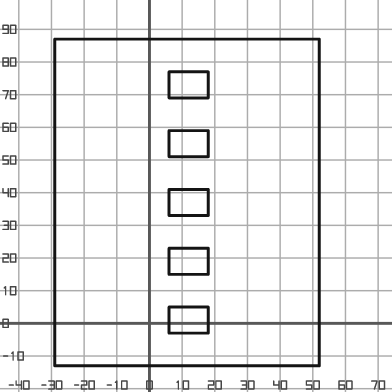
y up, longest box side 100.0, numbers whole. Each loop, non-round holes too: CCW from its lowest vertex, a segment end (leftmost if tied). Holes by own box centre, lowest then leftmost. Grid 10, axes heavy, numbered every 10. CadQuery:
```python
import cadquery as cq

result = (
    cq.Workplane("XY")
    .moveTo(-29.0, -13.0)
    .lineTo(52.0, -13.0)
    .lineTo(52.0, 87.0)
    .lineTo(-29.0, 87.0)
    .close()
    .moveTo(6.0, -3.0)
    .lineTo(18.0, -3.0)
    .lineTo(18.0, 5.0)
    .lineTo(6.0, 5.0)
    .close()
    .moveTo(6.0, 15.0)
    .lineTo(18.0, 15.0)
    .lineTo(18.0, 23.0)
    .lineTo(6.0, 23.0)
    .close()
    .moveTo(6.0, 33.0)
    .lineTo(18.0, 33.0)
    .lineTo(18.0, 41.0)
    .lineTo(6.0, 41.0)
    .close()
    .moveTo(6.0, 51.0)
    .lineTo(18.0, 51.0)
    .lineTo(18.0, 59.0)
    .lineTo(6.0, 59.0)
    .close()
    .moveTo(6.0, 69.0)
    .lineTo(18.0, 69.0)
    .lineTo(18.0, 77.0)
    .lineTo(6.0, 77.0)
    .close()
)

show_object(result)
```